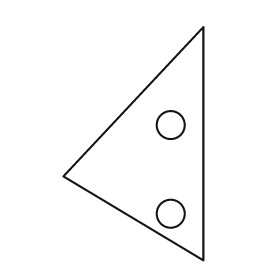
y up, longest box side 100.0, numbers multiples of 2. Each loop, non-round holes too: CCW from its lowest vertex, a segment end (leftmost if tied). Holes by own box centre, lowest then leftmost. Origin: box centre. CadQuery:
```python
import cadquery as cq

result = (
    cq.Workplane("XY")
    .moveTo(30.0, -50.0)
    .lineTo(30.0, 50.0)
    .lineTo(-30.0, -14.0)
    .close()
    .moveTo(16.0, -30.0)
    .circle(6.0)
    .moveTo(16.0, 8.0)
    .circle(6.0)
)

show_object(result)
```